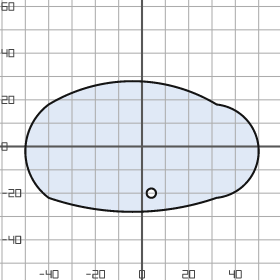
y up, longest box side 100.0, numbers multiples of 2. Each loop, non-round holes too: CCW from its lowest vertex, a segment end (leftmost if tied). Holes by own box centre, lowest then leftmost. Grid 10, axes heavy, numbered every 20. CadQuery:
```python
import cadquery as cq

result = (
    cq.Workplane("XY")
    .moveTo(-40.0, -22.0)
    .threePointArc((-4.0, -28.0), (32.0, -22.0))
    .threePointArc((50.0, -2.0), (32.0, 18.0))
    .threePointArc((-4.0, 28.0), (-40.0, 18.0))
    .threePointArc((-50.0, -2.0), (-40.0, -22.0))
    .close()
    .moveTo(4.0, -20.0)
    .circle(2.0)
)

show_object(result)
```